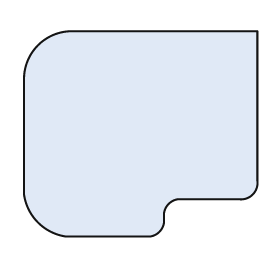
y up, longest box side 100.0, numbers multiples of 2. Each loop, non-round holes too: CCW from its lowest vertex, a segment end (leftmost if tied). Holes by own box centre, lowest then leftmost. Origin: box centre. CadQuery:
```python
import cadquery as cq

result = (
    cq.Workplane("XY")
    .moveTo(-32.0, -44.0)
    .lineTo(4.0, -44.0)
    .threePointArc((8.0, -42.0), (10.0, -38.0))
    .lineTo(10.0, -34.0)
    .threePointArc((12.0, -30.0), (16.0, -28.0))
    .lineTo(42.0, -28.0)
    .threePointArc((48.0, -26.0), (50.0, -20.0))
    .lineTo(50.0, 44.0)
    .lineTo(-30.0, 44.0)
    .threePointArc((-44.0, 38.0), (-50.0, 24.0))
    .lineTo(-50.0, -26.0)
    .threePointArc((-44.0, -38.0), (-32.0, -44.0))
    .close()
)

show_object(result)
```